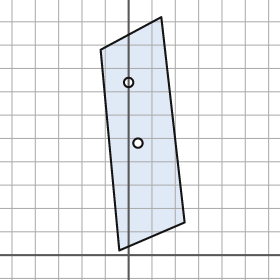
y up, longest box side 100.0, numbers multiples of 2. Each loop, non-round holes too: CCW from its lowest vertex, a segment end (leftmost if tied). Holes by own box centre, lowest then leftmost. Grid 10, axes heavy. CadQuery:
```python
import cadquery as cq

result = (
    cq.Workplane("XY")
    .moveTo(-4.0, 2.0)
    .lineTo(24.0, 14.0)
    .lineTo(14.0, 102.0)
    .lineTo(-12.0, 88.0)
    .close()
    .moveTo(4.0, 48.0)
    .circle(2.0)
    .moveTo(0.0, 74.0)
    .circle(2.0)
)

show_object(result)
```